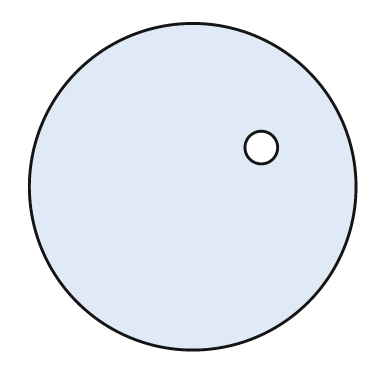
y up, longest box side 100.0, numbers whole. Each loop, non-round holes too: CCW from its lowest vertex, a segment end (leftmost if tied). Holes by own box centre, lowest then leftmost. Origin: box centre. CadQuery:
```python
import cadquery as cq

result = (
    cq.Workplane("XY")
    .moveTo(0.0, 0.0)
    .circle(50.0)
    .moveTo(21.0, 12.0)
    .circle(5.0)
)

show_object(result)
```